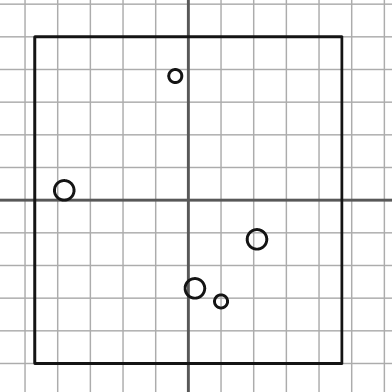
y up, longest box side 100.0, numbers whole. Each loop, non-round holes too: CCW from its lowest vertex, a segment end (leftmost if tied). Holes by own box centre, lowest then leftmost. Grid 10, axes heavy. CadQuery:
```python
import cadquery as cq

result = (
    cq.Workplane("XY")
    .moveTo(-47.0, -50.0)
    .lineTo(47.0, -50.0)
    .lineTo(47.0, 50.0)
    .lineTo(-47.0, 50.0)
    .close()
    .moveTo(10.0, -31.0)
    .circle(2.0)
    .moveTo(2.0, -27.0)
    .circle(3.0)
    .moveTo(21.0, -12.0)
    .circle(3.0)
    .moveTo(-38.0, 3.0)
    .circle(3.0)
    .moveTo(-4.0, 38.0)
    .circle(2.0)
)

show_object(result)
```